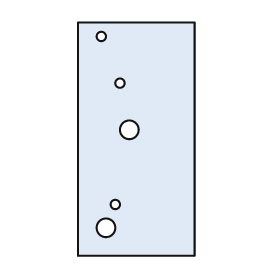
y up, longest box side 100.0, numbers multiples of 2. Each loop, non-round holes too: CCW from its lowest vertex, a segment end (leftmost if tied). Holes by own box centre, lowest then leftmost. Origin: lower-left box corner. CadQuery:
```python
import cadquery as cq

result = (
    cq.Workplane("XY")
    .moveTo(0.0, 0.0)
    .lineTo(50.0, 0.0)
    .lineTo(50.0, 100.0)
    .lineTo(0.0, 100.0)
    .close()
    .moveTo(12.0, 12.0)
    .circle(4.0)
    .moveTo(16.0, 22.0)
    .circle(2.0)
    .moveTo(22.0, 54.0)
    .circle(4.0)
    .moveTo(18.0, 74.0)
    .circle(2.0)
    .moveTo(10.0, 94.0)
    .circle(2.0)
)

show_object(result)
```